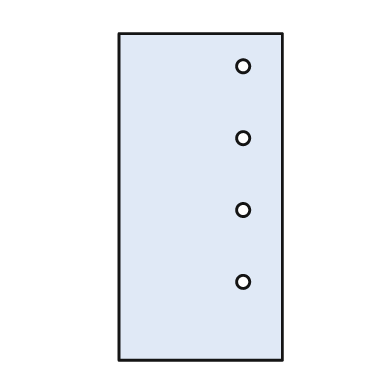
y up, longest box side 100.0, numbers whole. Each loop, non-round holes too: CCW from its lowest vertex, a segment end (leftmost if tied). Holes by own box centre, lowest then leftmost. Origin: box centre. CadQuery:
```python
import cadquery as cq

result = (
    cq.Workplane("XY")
    .moveTo(-25.0, -50.0)
    .lineTo(25.0, -50.0)
    .lineTo(25.0, 50.0)
    .lineTo(-25.0, 50.0)
    .close()
    .moveTo(13.0, -26.0)
    .circle(2.0)
    .moveTo(13.0, -4.0)
    .circle(2.0)
    .moveTo(13.0, 18.0)
    .circle(2.0)
    .moveTo(13.0, 40.0)
    .circle(2.0)
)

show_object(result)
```